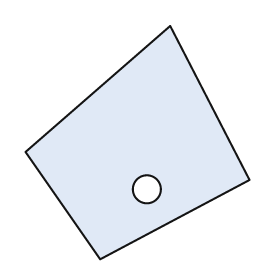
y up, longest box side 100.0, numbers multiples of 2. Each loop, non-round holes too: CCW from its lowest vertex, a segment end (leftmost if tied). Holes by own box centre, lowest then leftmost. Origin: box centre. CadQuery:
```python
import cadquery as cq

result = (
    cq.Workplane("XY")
    .moveTo(-16.0, -50.0)
    .lineTo(48.0, -16.0)
    .lineTo(14.0, 50.0)
    .lineTo(-48.0, -4.0)
    .close()
    .moveTo(4.0, -20.0)
    .circle(6.0)
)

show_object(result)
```